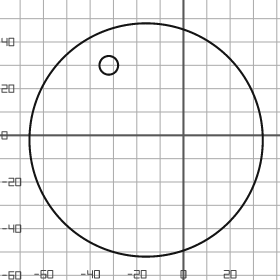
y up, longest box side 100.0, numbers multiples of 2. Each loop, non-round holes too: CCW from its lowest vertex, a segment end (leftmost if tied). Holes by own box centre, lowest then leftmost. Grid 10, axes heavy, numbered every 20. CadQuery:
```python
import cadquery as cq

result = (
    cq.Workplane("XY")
    .moveTo(-16.0, -2.0)
    .circle(50.0)
    .moveTo(-32.0, 30.0)
    .circle(4.0)
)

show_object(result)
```